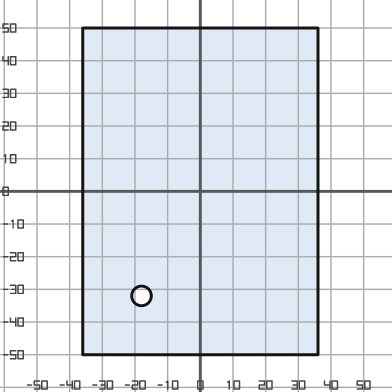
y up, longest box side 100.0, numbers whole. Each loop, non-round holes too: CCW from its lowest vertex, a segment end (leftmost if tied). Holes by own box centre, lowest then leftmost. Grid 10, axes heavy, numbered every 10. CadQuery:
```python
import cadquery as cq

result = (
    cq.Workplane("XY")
    .moveTo(-36.0, -50.0)
    .lineTo(36.0, -50.0)
    .lineTo(36.0, 50.0)
    .lineTo(-36.0, 50.0)
    .close()
    .moveTo(-18.0, -32.0)
    .circle(3.0)
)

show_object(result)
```